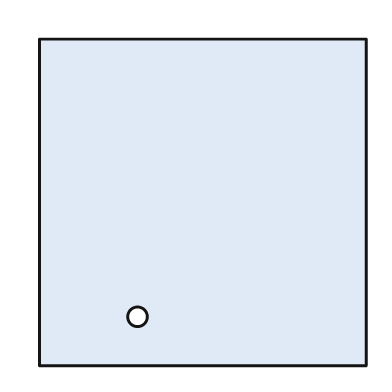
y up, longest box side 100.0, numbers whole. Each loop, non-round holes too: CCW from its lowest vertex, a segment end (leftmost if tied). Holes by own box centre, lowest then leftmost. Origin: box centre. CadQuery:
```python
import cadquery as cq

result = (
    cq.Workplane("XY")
    .moveTo(-50.0, -50.0)
    .lineTo(50.0, -50.0)
    .lineTo(50.0, 50.0)
    .lineTo(-50.0, 50.0)
    .close()
    .moveTo(-20.0, -35.0)
    .circle(3.0)
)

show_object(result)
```